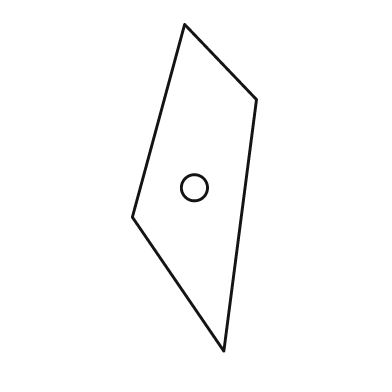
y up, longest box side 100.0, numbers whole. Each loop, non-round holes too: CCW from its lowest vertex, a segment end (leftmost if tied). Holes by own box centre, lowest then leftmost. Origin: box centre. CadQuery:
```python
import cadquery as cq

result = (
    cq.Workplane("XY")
    .moveTo(9.0, -50.0)
    .lineTo(19.0, 27.0)
    .lineTo(-3.0, 50.0)
    .lineTo(-19.0, -9.0)
    .close()
    .moveTo(0.0, 0.0)
    .circle(4.0)
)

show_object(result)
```